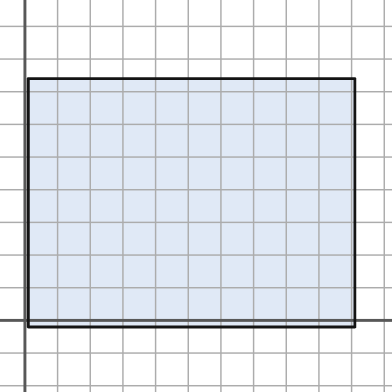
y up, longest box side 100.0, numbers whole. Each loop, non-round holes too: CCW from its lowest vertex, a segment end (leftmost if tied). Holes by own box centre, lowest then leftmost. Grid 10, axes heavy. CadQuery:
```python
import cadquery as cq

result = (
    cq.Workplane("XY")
    .moveTo(1.0, -2.0)
    .lineTo(101.0, -2.0)
    .lineTo(101.0, 74.0)
    .lineTo(1.0, 74.0)
    .close()
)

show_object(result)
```